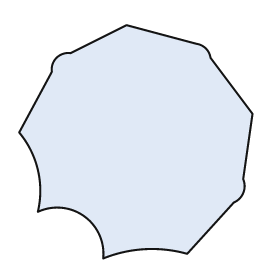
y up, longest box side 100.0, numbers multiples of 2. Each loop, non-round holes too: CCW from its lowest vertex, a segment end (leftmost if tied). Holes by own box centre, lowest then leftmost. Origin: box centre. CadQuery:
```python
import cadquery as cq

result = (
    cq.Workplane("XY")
    .moveTo(-14.0, -50.0)
    .threePointArc((4.0, -46.0), (22.0, -48.0))
    .lineTo(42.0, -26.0)
    .threePointArc((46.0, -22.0), (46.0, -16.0))
    .lineTo(50.0, 12.0)
    .lineTo(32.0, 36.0)
    .threePointArc((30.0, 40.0), (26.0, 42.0))
    .lineTo(-4.0, 50.0)
    .lineTo(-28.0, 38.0)
    .threePointArc((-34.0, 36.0), (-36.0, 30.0))
    .lineTo(-50.0, 4.0)
    .threePointArc((-42.0, -12.0), (-42.0, -30.0))
    .threePointArc((-22.0, -32.0), (-14.0, -50.0))
    .close()
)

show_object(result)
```